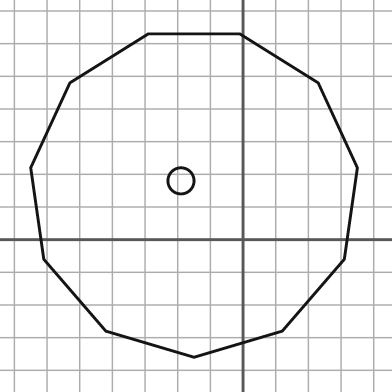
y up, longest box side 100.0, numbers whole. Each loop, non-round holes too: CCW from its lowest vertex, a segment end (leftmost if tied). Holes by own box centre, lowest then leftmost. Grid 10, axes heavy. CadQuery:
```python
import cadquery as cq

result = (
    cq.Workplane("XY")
    .moveTo(-15.0, -36.0)
    .lineTo(12.0, -28.0)
    .lineTo(31.0, -6.0)
    .lineTo(35.0, 22.0)
    .lineTo(23.0, 48.0)
    .lineTo(-1.0, 63.0)
    .lineTo(-29.0, 63.0)
    .lineTo(-53.0, 48.0)
    .lineTo(-65.0, 22.0)
    .lineTo(-61.0, -6.0)
    .lineTo(-42.0, -28.0)
    .close()
    .moveTo(-19.0, 18.0)
    .circle(4.0)
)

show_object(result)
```